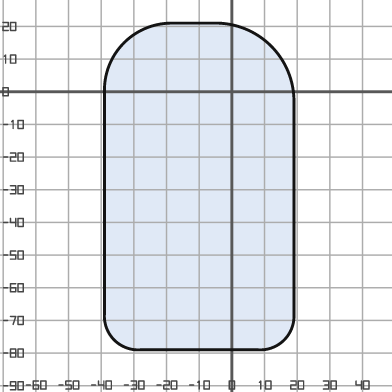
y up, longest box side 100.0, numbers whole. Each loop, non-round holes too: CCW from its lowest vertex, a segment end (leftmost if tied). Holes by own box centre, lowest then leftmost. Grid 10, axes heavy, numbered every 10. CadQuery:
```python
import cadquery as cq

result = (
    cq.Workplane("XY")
    .moveTo(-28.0, -79.0)
    .lineTo(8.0, -79.0)
    .threePointArc((16.0, -76.0), (19.0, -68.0))
    .lineTo(19.0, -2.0)
    .threePointArc((12.0, 14.0), (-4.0, 21.0))
    .lineTo(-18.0, 21.0)
    .threePointArc((-33.0, 15.0), (-39.0, 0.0))
    .lineTo(-39.0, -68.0)
    .threePointArc((-36.0, -76.0), (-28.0, -79.0))
    .close()
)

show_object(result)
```